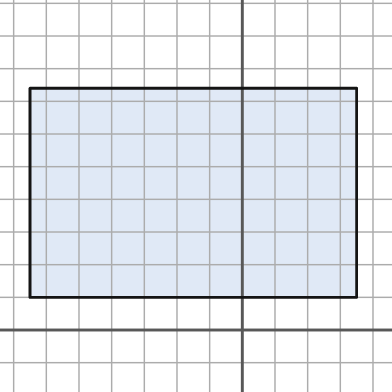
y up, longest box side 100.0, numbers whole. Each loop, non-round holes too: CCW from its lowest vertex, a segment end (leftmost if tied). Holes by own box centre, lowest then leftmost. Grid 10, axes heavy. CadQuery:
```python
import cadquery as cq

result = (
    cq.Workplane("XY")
    .moveTo(-65.0, 10.0)
    .lineTo(35.0, 10.0)
    .lineTo(35.0, 74.0)
    .lineTo(-65.0, 74.0)
    .close()
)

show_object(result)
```